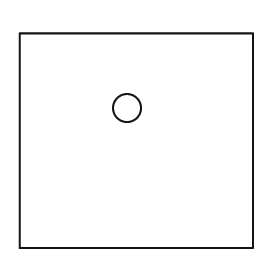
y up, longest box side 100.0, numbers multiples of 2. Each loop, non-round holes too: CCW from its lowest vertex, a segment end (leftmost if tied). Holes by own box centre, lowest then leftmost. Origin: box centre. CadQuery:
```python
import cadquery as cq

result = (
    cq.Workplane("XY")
    .moveTo(-50.0, -46.0)
    .lineTo(50.0, -46.0)
    .lineTo(50.0, 46.0)
    .lineTo(-50.0, 46.0)
    .close()
    .moveTo(-4.0, 14.0)
    .circle(6.0)
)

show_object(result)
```